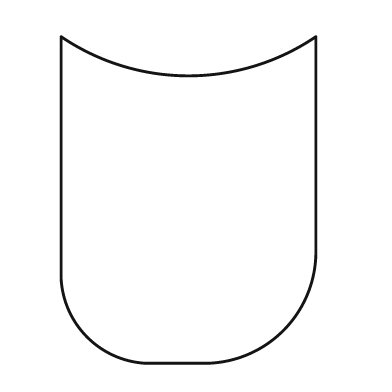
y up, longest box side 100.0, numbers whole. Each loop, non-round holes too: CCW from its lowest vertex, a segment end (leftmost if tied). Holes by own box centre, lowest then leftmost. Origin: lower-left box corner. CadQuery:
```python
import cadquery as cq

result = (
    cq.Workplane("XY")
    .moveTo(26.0, 0.0)
    .lineTo(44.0, 0.0)
    .threePointArc((68.0, 10.0), (78.0, 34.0))
    .lineTo(78.0, 100.0)
    .threePointArc((39.0, 88.0), (0.0, 100.0))
    .lineTo(0.0, 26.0)
    .threePointArc((8.0, 8.0), (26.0, 0.0))
    .close()
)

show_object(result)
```